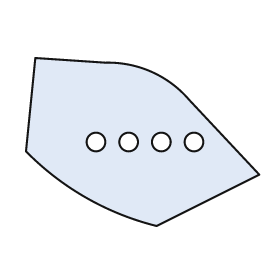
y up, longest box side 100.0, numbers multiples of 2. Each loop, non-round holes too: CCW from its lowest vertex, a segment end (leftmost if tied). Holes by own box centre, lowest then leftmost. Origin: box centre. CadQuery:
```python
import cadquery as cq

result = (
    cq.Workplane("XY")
    .moveTo(6.0, -36.0)
    .lineTo(50.0, -14.0)
    .lineTo(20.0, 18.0)
    .threePointArc((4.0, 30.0), (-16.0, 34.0))
    .lineTo(-46.0, 36.0)
    .lineTo(-50.0, -4.0)
    .threePointArc((-24.0, -24.0), (6.0, -36.0))
    .close()
    .moveTo(-20.0, 0.0)
    .circle(4.0)
    .moveTo(-6.0, 0.0)
    .circle(4.0)
    .moveTo(8.0, 0.0)
    .circle(4.0)
    .moveTo(22.0, 0.0)
    .circle(4.0)
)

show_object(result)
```